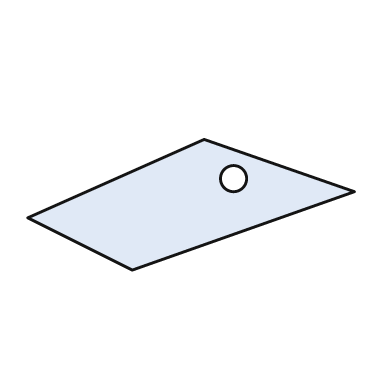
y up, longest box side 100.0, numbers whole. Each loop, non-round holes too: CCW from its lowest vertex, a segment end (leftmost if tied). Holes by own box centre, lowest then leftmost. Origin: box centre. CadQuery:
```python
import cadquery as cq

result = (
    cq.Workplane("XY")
    .moveTo(-18.0, -20.0)
    .lineTo(50.0, 4.0)
    .lineTo(4.0, 20.0)
    .lineTo(-50.0, -4.0)
    .close()
    .moveTo(13.0, 8.0)
    .circle(4.0)
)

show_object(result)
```